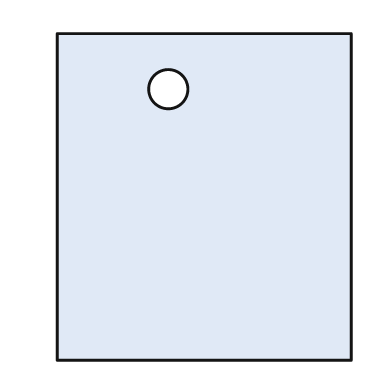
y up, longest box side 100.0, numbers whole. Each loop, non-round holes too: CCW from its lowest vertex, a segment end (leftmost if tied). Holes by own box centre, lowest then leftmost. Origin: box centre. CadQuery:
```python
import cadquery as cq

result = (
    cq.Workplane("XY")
    .moveTo(-45.0, -50.0)
    .lineTo(45.0, -50.0)
    .lineTo(45.0, 50.0)
    .lineTo(-45.0, 50.0)
    .close()
    .moveTo(-11.0, 33.0)
    .circle(6.0)
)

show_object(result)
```